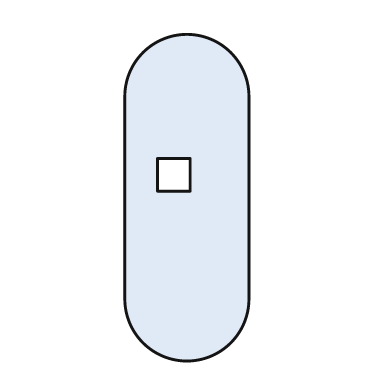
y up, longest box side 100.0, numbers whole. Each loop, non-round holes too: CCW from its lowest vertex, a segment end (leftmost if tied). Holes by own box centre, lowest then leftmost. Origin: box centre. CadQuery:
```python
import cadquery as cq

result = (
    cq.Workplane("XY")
    .moveTo(-19.0, -31.0)
    .threePointArc((0.0, -50.0), (19.0, -31.0))
    .lineTo(19.0, 31.0)
    .threePointArc((0.0, 50.0), (-19.0, 31.0))
    .close()
    .moveTo(-9.0, 2.0)
    .lineTo(1.0, 2.0)
    .lineTo(1.0, 12.0)
    .lineTo(-9.0, 12.0)
    .close()
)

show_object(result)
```